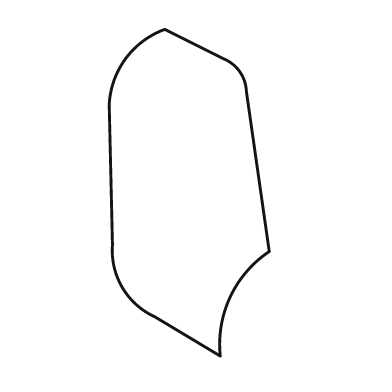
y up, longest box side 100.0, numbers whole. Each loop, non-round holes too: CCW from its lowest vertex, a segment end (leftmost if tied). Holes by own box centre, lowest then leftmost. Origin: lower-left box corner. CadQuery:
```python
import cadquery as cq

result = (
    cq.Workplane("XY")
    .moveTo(34.0, 0.0)
    .threePointArc((37.0, 18.0), (49.0, 32.0))
    .lineTo(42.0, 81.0)
    .threePointArc((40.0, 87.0), (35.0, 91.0))
    .lineTo(17.0, 100.0)
    .threePointArc((5.0, 91.0), (0.0, 77.0))
    .lineTo(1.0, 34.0)
    .threePointArc((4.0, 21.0), (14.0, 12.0))
    .close()
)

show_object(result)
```